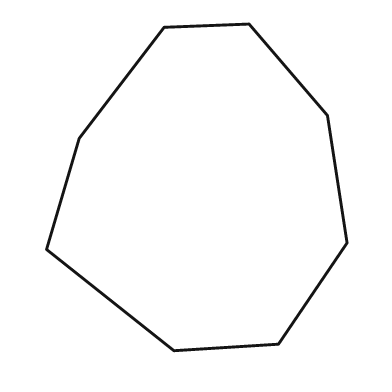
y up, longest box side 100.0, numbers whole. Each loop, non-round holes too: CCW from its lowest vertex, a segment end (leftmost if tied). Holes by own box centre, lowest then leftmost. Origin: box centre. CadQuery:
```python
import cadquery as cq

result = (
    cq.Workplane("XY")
    .moveTo(-7.0, -50.0)
    .lineTo(25.0, -48.0)
    .lineTo(46.0, -17.0)
    .lineTo(40.0, 22.0)
    .lineTo(16.0, 50.0)
    .lineTo(-10.0, 49.0)
    .lineTo(-36.0, 15.0)
    .lineTo(-46.0, -19.0)
    .close()
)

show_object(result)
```